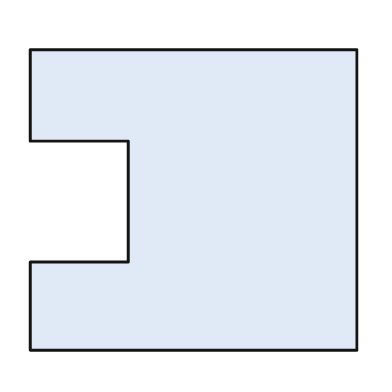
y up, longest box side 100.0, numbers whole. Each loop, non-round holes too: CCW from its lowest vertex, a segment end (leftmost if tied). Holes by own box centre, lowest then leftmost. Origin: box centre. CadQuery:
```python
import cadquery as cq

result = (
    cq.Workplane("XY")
    .moveTo(-50.0, -46.0)
    .lineTo(50.0, -46.0)
    .lineTo(50.0, 46.0)
    .lineTo(-50.0, 46.0)
    .lineTo(-50.0, 18.0)
    .lineTo(-20.0, 18.0)
    .lineTo(-20.0, -19.0)
    .lineTo(-50.0, -19.0)
    .close()
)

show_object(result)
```